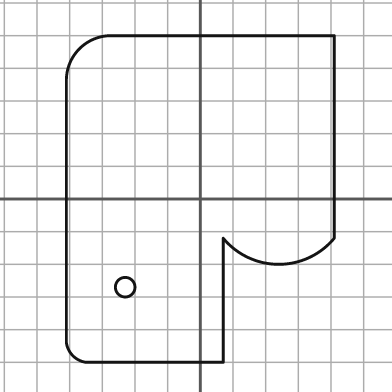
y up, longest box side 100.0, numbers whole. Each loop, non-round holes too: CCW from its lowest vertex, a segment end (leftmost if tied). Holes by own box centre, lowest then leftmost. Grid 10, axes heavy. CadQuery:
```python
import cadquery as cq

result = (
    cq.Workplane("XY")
    .moveTo(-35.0, -50.0)
    .lineTo(7.0, -50.0)
    .lineTo(7.0, -12.0)
    .threePointArc((24.0, -20.0), (41.0, -12.0))
    .lineTo(41.0, 50.0)
    .lineTo(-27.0, 50.0)
    .threePointArc((-37.0, 46.0), (-41.0, 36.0))
    .lineTo(-41.0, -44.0)
    .threePointArc((-39.0, -48.0), (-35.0, -50.0))
    .close()
    .moveTo(-23.0, -27.0)
    .circle(3.0)
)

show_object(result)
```